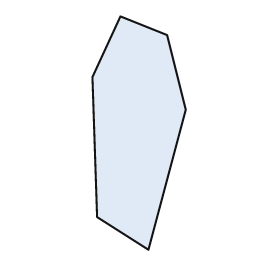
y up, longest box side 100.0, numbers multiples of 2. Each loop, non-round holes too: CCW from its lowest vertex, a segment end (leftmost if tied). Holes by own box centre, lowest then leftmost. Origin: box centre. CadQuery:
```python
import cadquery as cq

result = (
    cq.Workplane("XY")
    .moveTo(4.0, -50.0)
    .lineTo(20.0, 10.0)
    .lineTo(12.0, 42.0)
    .lineTo(-8.0, 50.0)
    .lineTo(-20.0, 24.0)
    .lineTo(-18.0, -36.0)
    .close()
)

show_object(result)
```